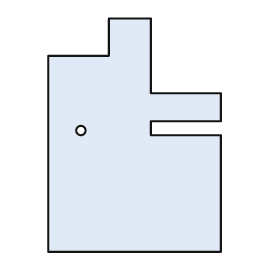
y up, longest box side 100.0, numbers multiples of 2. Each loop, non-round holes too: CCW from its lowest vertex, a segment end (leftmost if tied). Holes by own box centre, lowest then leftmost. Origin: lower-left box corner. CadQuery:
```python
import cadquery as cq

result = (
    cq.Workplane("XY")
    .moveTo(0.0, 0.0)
    .lineTo(74.0, 0.0)
    .lineTo(74.0, 50.0)
    .lineTo(44.0, 50.0)
    .lineTo(44.0, 56.0)
    .lineTo(74.0, 56.0)
    .lineTo(74.0, 68.0)
    .lineTo(44.0, 68.0)
    .lineTo(44.0, 100.0)
    .lineTo(26.0, 100.0)
    .lineTo(26.0, 84.0)
    .lineTo(0.0, 84.0)
    .close()
    .moveTo(14.0, 52.0)
    .circle(2.0)
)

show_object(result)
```